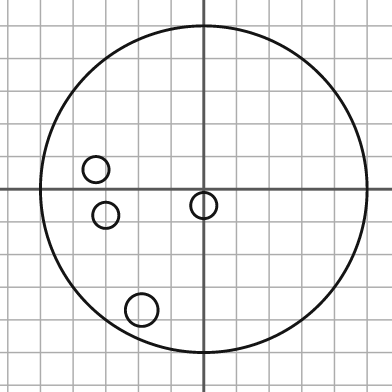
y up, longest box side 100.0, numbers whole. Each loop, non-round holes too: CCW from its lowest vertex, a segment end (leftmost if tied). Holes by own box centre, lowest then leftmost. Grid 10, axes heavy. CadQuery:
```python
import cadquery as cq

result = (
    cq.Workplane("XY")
    .moveTo(0.0, 0.0)
    .circle(50.0)
    .moveTo(-19.0, -37.0)
    .circle(5.0)
    .moveTo(-30.0, -8.0)
    .circle(4.0)
    .moveTo(0.0, -5.0)
    .circle(4.0)
    .moveTo(-33.0, 6.0)
    .circle(4.0)
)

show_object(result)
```